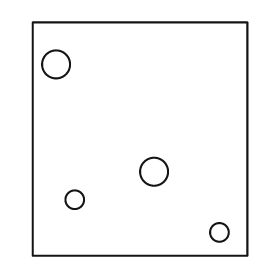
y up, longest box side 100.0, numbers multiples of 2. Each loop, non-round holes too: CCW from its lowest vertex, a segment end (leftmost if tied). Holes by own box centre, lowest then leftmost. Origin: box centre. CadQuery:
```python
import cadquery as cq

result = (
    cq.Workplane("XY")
    .moveTo(-46.0, -50.0)
    .lineTo(46.0, -50.0)
    .lineTo(46.0, 50.0)
    .lineTo(-46.0, 50.0)
    .close()
    .moveTo(34.0, -40.0)
    .circle(4.0)
    .moveTo(-28.0, -26.0)
    .circle(4.0)
    .moveTo(6.0, -14.0)
    .circle(6.0)
    .moveTo(-36.0, 32.0)
    .circle(6.0)
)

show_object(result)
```